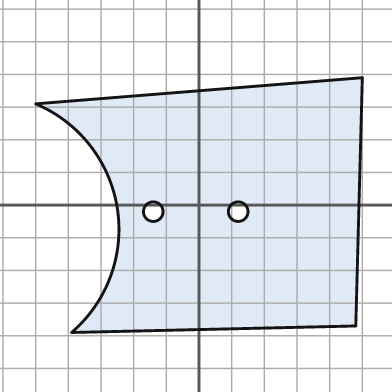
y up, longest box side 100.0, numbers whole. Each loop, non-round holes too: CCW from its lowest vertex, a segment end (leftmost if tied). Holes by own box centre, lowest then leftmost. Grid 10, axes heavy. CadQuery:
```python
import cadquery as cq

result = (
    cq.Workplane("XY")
    .moveTo(-39.0, -39.0)
    .lineTo(48.0, -37.0)
    .lineTo(50.0, 39.0)
    .lineTo(-50.0, 31.0)
    .threePointArc((-25.0, -1.0), (-39.0, -39.0))
    .close()
    .moveTo(-14.0, -2.0)
    .circle(3.0)
    .moveTo(12.0, -2.0)
    .circle(3.0)
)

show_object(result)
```